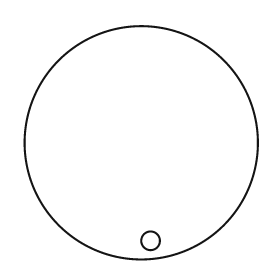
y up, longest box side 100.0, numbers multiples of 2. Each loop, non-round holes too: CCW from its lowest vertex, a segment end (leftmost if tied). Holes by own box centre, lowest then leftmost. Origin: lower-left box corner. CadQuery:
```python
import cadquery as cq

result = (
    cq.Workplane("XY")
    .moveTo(50.0, 50.0)
    .circle(50.0)
    .moveTo(54.0, 8.0)
    .circle(4.0)
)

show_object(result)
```